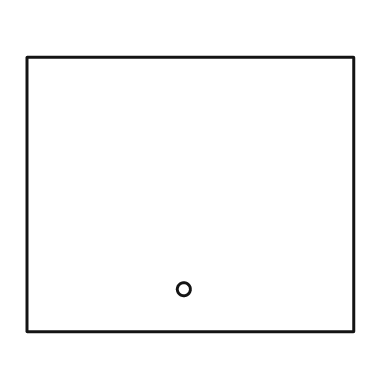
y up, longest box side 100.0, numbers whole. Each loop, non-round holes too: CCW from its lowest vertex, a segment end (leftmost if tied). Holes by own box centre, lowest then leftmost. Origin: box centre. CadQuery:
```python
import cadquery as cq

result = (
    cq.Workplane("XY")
    .moveTo(-50.0, -42.0)
    .lineTo(50.0, -42.0)
    .lineTo(50.0, 42.0)
    .lineTo(-50.0, 42.0)
    .close()
    .moveTo(-2.0, -29.0)
    .circle(2.0)
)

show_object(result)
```